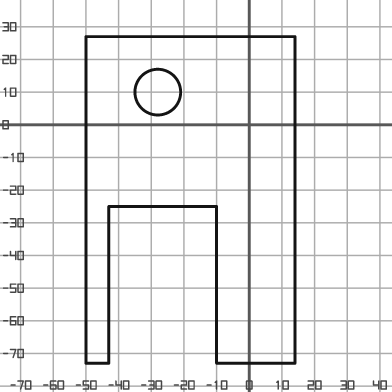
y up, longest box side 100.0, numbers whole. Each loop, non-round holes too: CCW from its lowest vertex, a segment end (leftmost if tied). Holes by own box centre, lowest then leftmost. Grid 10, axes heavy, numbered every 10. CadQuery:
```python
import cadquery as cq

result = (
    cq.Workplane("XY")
    .moveTo(-50.0, -73.0)
    .lineTo(-43.0, -73.0)
    .lineTo(-43.0, -25.0)
    .lineTo(-10.0, -25.0)
    .lineTo(-10.0, -73.0)
    .lineTo(14.0, -73.0)
    .lineTo(14.0, 27.0)
    .lineTo(-50.0, 27.0)
    .close()
    .moveTo(-28.0, 10.0)
    .circle(7.0)
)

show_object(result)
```